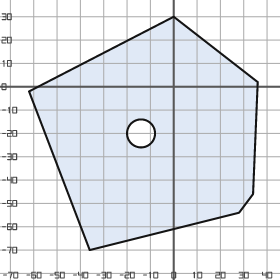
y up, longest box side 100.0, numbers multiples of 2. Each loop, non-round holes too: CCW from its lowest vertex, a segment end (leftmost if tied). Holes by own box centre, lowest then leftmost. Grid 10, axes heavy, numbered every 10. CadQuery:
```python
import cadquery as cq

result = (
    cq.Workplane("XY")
    .moveTo(-36.0, -70.0)
    .lineTo(28.0, -54.0)
    .lineTo(34.0, -46.0)
    .lineTo(36.0, 2.0)
    .lineTo(0.0, 30.0)
    .lineTo(-62.0, -2.0)
    .close()
    .moveTo(-14.0, -20.0)
    .circle(6.0)
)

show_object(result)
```